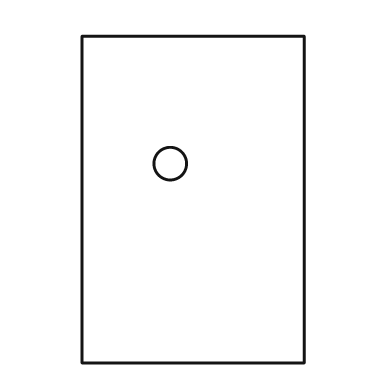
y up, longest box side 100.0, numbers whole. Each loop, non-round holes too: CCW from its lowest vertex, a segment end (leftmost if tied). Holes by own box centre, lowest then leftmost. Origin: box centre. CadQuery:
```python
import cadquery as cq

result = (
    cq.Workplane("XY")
    .moveTo(-34.0, -50.0)
    .lineTo(34.0, -50.0)
    .lineTo(34.0, 50.0)
    .lineTo(-34.0, 50.0)
    .close()
    .moveTo(-7.0, 11.0)
    .circle(5.0)
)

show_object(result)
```